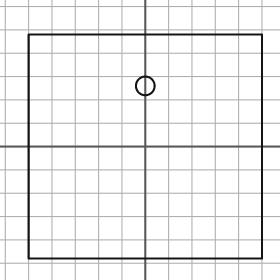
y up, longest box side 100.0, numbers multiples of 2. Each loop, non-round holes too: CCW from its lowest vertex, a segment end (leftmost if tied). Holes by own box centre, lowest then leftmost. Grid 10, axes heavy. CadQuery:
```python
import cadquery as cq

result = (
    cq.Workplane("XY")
    .moveTo(-50.0, -48.0)
    .lineTo(50.0, -48.0)
    .lineTo(50.0, 48.0)
    .lineTo(-50.0, 48.0)
    .close()
    .moveTo(0.0, 26.0)
    .circle(4.0)
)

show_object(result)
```